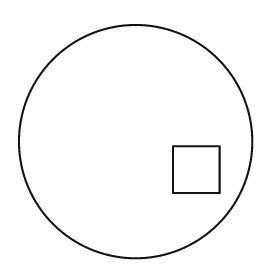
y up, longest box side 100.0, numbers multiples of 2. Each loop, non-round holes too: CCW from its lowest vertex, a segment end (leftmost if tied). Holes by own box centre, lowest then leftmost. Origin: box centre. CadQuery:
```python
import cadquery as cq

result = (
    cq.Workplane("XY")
    .moveTo(0.0, 0.0)
    .circle(50.0)
    .moveTo(16.0, -22.0)
    .lineTo(36.0, -22.0)
    .lineTo(36.0, -2.0)
    .lineTo(16.0, -2.0)
    .close()
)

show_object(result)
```